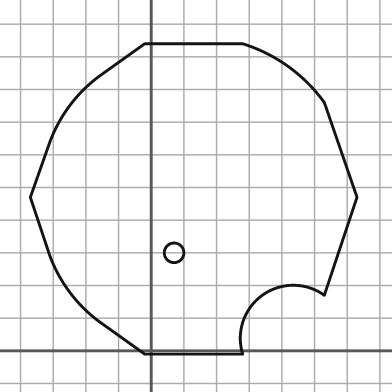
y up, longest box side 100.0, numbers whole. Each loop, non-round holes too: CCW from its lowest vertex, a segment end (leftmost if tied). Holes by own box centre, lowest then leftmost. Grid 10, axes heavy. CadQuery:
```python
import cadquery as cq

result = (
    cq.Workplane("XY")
    .moveTo(-2.0, -1.0)
    .lineTo(28.0, -1.0)
    .threePointArc((34.0, 17.0), (53.0, 17.0))
    .lineTo(63.0, 47.0)
    .lineTo(53.0, 76.0)
    .threePointArc((42.0, 87.0), (28.0, 94.0))
    .lineTo(-2.0, 94.0)
    .lineTo(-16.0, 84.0)
    .threePointArc((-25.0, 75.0), (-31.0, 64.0))
    .lineTo(-37.0, 47.0)
    .lineTo(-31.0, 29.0)
    .threePointArc((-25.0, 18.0), (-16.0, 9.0))
    .close()
    .moveTo(7.0, 30.0)
    .circle(3.0)
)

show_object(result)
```